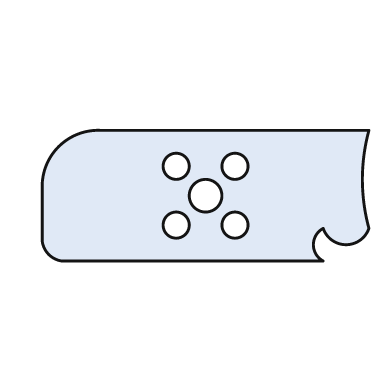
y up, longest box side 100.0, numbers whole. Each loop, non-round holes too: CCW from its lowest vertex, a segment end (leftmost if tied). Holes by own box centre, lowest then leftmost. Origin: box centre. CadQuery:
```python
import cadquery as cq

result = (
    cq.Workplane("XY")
    .moveTo(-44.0, -20.0)
    .lineTo(36.0, -20.0)
    .threePointArc((33.0, -15.0), (36.0, -10.0))
    .threePointArc((43.0, -15.0), (50.0, -10.0))
    .threePointArc((48.0, 5.0), (50.0, 20.0))
    .lineTo(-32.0, 20.0)
    .threePointArc((-45.0, 15.0), (-50.0, 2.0))
    .lineTo(-50.0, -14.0)
    .threePointArc((-48.0, -18.0), (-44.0, -20.0))
    .close()
    .moveTo(-9.0, -9.0)
    .circle(4.0)
    .moveTo(9.0, -9.0)
    .circle(4.0)
    .moveTo(0.0, 0.0)
    .circle(5.0)
    .moveTo(-9.0, 9.0)
    .circle(4.0)
    .moveTo(9.0, 9.0)
    .circle(4.0)
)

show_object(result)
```